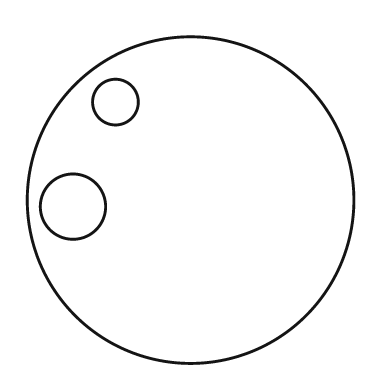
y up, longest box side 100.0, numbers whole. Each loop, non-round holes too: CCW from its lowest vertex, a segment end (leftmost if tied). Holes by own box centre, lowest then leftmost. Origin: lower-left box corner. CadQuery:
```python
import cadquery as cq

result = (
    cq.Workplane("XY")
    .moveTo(50.0, 50.0)
    .circle(50.0)
    .moveTo(14.0, 48.0)
    .circle(10.0)
    .moveTo(27.0, 80.0)
    .circle(7.0)
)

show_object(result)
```